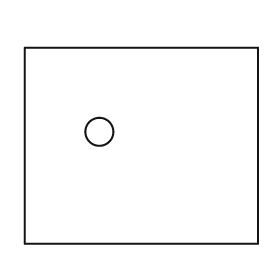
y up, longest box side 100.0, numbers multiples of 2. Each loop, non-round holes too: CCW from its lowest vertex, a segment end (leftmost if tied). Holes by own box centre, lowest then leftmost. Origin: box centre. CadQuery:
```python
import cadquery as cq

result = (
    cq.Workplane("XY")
    .moveTo(-50.0, -42.0)
    .lineTo(50.0, -42.0)
    .lineTo(50.0, 42.0)
    .lineTo(-50.0, 42.0)
    .close()
    .moveTo(-18.0, 6.0)
    .circle(6.0)
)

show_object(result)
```